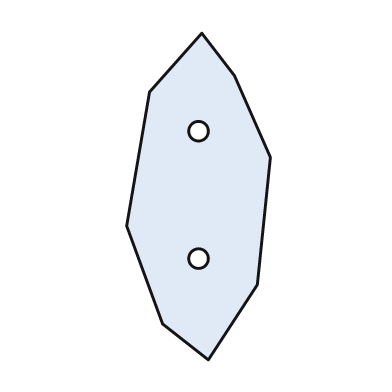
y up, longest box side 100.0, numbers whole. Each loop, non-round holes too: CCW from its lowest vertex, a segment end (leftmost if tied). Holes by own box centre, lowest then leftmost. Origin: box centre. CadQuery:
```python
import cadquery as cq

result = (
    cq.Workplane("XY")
    .moveTo(3.0, -50.0)
    .lineTo(18.0, -27.0)
    .lineTo(22.0, 12.0)
    .lineTo(11.0, 37.0)
    .lineTo(1.0, 50.0)
    .lineTo(-15.0, 32.0)
    .lineTo(-22.0, -9.0)
    .lineTo(-11.0, -39.0)
    .close()
    .moveTo(0.0, -19.0)
    .circle(3.0)
    .moveTo(0.0, 20.0)
    .circle(3.0)
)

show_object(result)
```